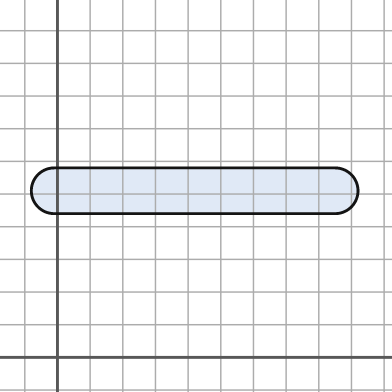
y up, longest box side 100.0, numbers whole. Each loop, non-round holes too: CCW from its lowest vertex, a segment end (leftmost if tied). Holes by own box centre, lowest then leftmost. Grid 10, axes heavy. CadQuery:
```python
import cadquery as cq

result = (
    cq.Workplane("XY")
    .moveTo(-1.0, 44.0)
    .lineTo(85.0, 44.0)
    .threePointArc((92.0, 51.0), (85.0, 58.0))
    .lineTo(-1.0, 58.0)
    .threePointArc((-8.0, 51.0), (-1.0, 44.0))
    .close()
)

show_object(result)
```